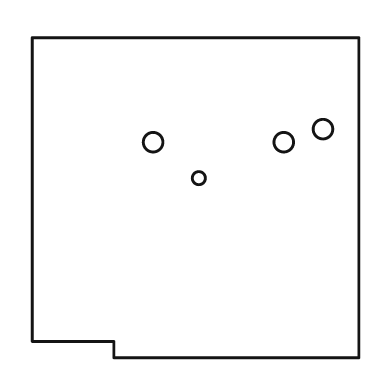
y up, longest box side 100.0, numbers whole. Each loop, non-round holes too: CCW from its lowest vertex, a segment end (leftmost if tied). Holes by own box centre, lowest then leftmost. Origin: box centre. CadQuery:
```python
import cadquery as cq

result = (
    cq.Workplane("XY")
    .moveTo(-25.0, -49.0)
    .lineTo(50.0, -49.0)
    .lineTo(50.0, 49.0)
    .lineTo(-50.0, 49.0)
    .lineTo(-50.0, -44.0)
    .lineTo(-25.0, -44.0)
    .close()
    .moveTo(1.0, 6.0)
    .circle(2.0)
    .moveTo(-13.0, 17.0)
    .circle(3.0)
    .moveTo(27.0, 17.0)
    .circle(3.0)
    .moveTo(39.0, 21.0)
    .circle(3.0)
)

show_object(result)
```